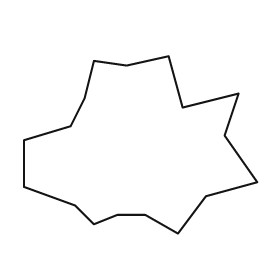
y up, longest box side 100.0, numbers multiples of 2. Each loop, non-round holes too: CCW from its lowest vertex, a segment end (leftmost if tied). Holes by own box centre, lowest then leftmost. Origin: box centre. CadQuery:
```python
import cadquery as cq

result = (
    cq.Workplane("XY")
    .moveTo(16.0, -38.0)
    .lineTo(28.0, -22.0)
    .lineTo(50.0, -16.0)
    .lineTo(36.0, 4.0)
    .lineTo(42.0, 22.0)
    .lineTo(18.0, 16.0)
    .lineTo(12.0, 38.0)
    .lineTo(-6.0, 34.0)
    .lineTo(-20.0, 36.0)
    .lineTo(-24.0, 20.0)
    .lineTo(-30.0, 8.0)
    .lineTo(-50.0, 2.0)
    .lineTo(-50.0, -18.0)
    .lineTo(-28.0, -26.0)
    .lineTo(-20.0, -34.0)
    .lineTo(-10.0, -30.0)
    .lineTo(2.0, -30.0)
    .close()
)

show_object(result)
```